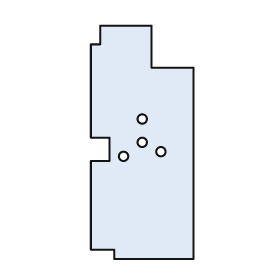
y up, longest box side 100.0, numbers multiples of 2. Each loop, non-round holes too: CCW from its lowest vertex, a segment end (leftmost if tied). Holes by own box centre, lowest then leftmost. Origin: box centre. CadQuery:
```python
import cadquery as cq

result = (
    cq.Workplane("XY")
    .moveTo(-12.0, -50.0)
    .lineTo(22.0, -50.0)
    .lineTo(22.0, 32.0)
    .lineTo(4.0, 32.0)
    .lineTo(4.0, 50.0)
    .lineTo(-18.0, 50.0)
    .lineTo(-18.0, 42.0)
    .lineTo(-22.0, 42.0)
    .lineTo(-22.0, 2.0)
    .lineTo(-14.0, 2.0)
    .lineTo(-14.0, -8.0)
    .lineTo(-22.0, -8.0)
    .lineTo(-22.0, -46.0)
    .lineTo(-12.0, -46.0)
    .close()
    .moveTo(-8.0, -6.0)
    .circle(2.0)
    .moveTo(8.0, -4.0)
    .circle(2.0)
    .moveTo(0.0, 0.0)
    .circle(2.0)
    .moveTo(0.0, 10.0)
    .circle(2.0)
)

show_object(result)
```